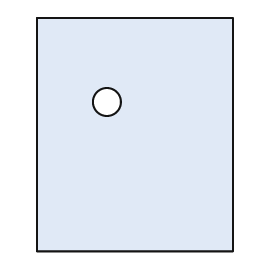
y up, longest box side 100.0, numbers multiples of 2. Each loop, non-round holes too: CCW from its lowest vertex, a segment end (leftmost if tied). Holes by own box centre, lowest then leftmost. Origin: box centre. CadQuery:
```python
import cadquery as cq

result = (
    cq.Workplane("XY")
    .moveTo(-42.0, -50.0)
    .lineTo(42.0, -50.0)
    .lineTo(42.0, 50.0)
    .lineTo(-42.0, 50.0)
    .close()
    .moveTo(-12.0, 14.0)
    .circle(6.0)
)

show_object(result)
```